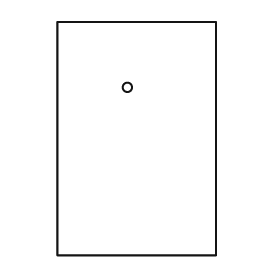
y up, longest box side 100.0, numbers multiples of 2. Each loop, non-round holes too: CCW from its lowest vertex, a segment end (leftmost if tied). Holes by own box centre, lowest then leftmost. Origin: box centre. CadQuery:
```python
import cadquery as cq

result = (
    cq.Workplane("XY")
    .moveTo(-34.0, -50.0)
    .lineTo(34.0, -50.0)
    .lineTo(34.0, 50.0)
    .lineTo(-34.0, 50.0)
    .close()
    .moveTo(-4.0, 22.0)
    .circle(2.0)
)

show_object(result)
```